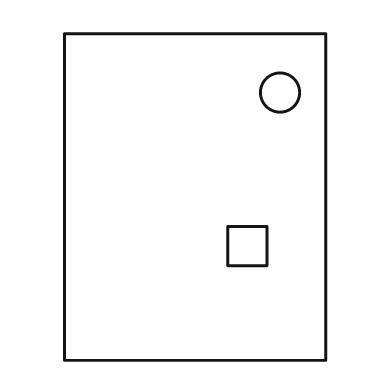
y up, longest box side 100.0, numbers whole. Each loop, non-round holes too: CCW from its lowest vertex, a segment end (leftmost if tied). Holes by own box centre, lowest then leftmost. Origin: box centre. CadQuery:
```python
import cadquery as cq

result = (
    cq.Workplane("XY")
    .moveTo(-40.0, -50.0)
    .lineTo(40.0, -50.0)
    .lineTo(40.0, 50.0)
    .lineTo(-40.0, 50.0)
    .close()
    .moveTo(10.0, -21.0)
    .lineTo(22.0, -21.0)
    .lineTo(22.0, -9.0)
    .lineTo(10.0, -9.0)
    .close()
    .moveTo(26.0, 32.0)
    .circle(6.0)
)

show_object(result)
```